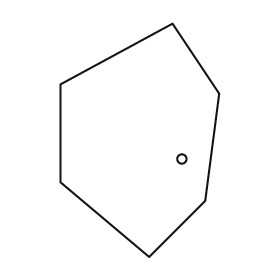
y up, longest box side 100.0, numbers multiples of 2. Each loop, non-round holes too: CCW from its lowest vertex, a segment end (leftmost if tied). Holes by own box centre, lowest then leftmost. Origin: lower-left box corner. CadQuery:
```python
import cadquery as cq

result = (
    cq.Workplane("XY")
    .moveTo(38.0, 0.0)
    .lineTo(62.0, 24.0)
    .lineTo(68.0, 70.0)
    .lineTo(48.0, 100.0)
    .lineTo(0.0, 74.0)
    .lineTo(0.0, 32.0)
    .close()
    .moveTo(52.0, 42.0)
    .circle(2.0)
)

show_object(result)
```